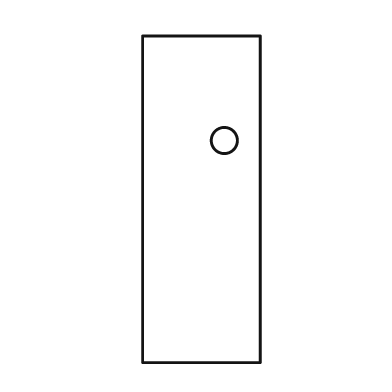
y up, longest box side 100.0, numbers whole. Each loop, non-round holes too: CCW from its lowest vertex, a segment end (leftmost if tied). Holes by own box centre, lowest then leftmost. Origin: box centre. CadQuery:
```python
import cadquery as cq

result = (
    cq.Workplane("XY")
    .moveTo(-18.0, -50.0)
    .lineTo(18.0, -50.0)
    .lineTo(18.0, 50.0)
    .lineTo(-18.0, 50.0)
    .close()
    .moveTo(7.0, 18.0)
    .circle(4.0)
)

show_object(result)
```